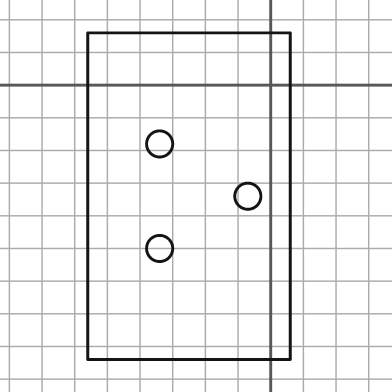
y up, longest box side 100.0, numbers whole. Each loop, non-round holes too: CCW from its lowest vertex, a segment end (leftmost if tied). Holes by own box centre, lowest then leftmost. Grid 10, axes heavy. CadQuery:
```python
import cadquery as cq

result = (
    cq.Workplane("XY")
    .moveTo(-56.0, -84.0)
    .lineTo(6.0, -84.0)
    .lineTo(6.0, 16.0)
    .lineTo(-56.0, 16.0)
    .close()
    .moveTo(-34.0, -50.0)
    .circle(4.0)
    .moveTo(-7.0, -34.0)
    .circle(4.0)
    .moveTo(-34.0, -18.0)
    .circle(4.0)
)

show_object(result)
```